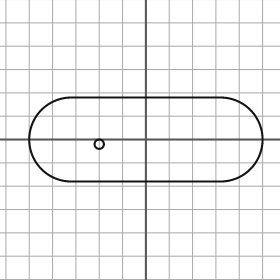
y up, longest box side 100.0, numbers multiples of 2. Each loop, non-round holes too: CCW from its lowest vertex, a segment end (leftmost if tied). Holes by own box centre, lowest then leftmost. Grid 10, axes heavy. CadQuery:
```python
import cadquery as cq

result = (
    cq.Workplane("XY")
    .moveTo(-32.0, -18.0)
    .lineTo(32.0, -18.0)
    .threePointArc((50.0, 0.0), (32.0, 18.0))
    .lineTo(-32.0, 18.0)
    .threePointArc((-50.0, 0.0), (-32.0, -18.0))
    .close()
    .moveTo(-20.0, -2.0)
    .circle(2.0)
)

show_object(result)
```